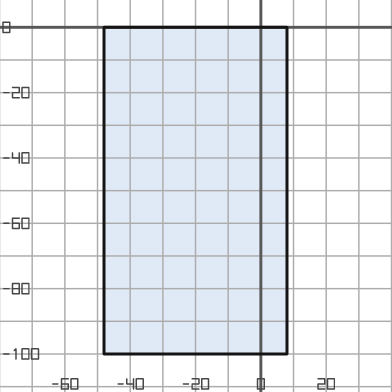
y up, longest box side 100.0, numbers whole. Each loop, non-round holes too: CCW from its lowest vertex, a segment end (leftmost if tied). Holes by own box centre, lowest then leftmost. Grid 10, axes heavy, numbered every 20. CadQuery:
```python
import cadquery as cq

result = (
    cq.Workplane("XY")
    .moveTo(-48.0, -100.0)
    .lineTo(8.0, -100.0)
    .lineTo(8.0, 0.0)
    .lineTo(-48.0, 0.0)
    .close()
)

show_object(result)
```